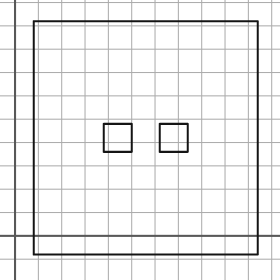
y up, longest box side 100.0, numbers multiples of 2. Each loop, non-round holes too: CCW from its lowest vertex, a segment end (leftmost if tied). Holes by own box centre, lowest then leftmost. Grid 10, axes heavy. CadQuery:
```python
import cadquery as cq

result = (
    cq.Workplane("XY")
    .moveTo(8.0, -8.0)
    .lineTo(104.0, -8.0)
    .lineTo(104.0, 92.0)
    .lineTo(8.0, 92.0)
    .close()
    .moveTo(38.0, 36.0)
    .lineTo(50.0, 36.0)
    .lineTo(50.0, 48.0)
    .lineTo(38.0, 48.0)
    .close()
    .moveTo(62.0, 36.0)
    .lineTo(74.0, 36.0)
    .lineTo(74.0, 48.0)
    .lineTo(62.0, 48.0)
    .close()
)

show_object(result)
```